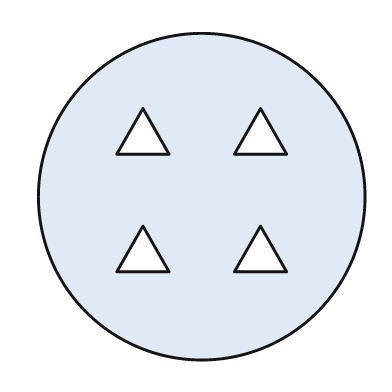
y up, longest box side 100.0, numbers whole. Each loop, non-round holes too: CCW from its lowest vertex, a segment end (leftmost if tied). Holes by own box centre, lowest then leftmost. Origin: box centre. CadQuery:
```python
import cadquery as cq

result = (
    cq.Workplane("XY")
    .moveTo(0.0, 0.0)
    .circle(50.0)
    .moveTo(-26.0, -23.0)
    .lineTo(-10.0, -23.0)
    .lineTo(-18.0, -9.0)
    .close()
    .moveTo(10.0, -23.0)
    .lineTo(26.0, -23.0)
    .lineTo(18.0, -9.0)
    .close()
    .moveTo(-26.0, 13.0)
    .lineTo(-10.0, 13.0)
    .lineTo(-18.0, 27.0)
    .close()
    .moveTo(10.0, 13.0)
    .lineTo(26.0, 13.0)
    .lineTo(18.0, 27.0)
    .close()
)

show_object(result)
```